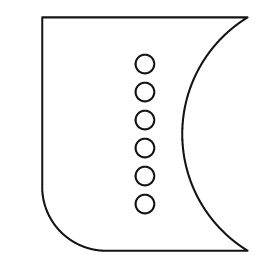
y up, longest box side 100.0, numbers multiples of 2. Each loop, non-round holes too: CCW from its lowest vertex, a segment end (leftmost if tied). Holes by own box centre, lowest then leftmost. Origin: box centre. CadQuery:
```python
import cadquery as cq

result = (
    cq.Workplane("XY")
    .moveTo(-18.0, -50.0)
    .lineTo(44.0, -50.0)
    .threePointArc((16.0, 0.0), (44.0, 50.0))
    .lineTo(-44.0, 50.0)
    .lineTo(-44.0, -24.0)
    .threePointArc((-36.0, -42.0), (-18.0, -50.0))
    .close()
    .moveTo(0.0, -30.0)
    .circle(4.0)
    .moveTo(0.0, -18.0)
    .circle(4.0)
    .moveTo(0.0, -6.0)
    .circle(4.0)
    .moveTo(0.0, 6.0)
    .circle(4.0)
    .moveTo(0.0, 18.0)
    .circle(4.0)
    .moveTo(0.0, 30.0)
    .circle(4.0)
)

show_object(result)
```